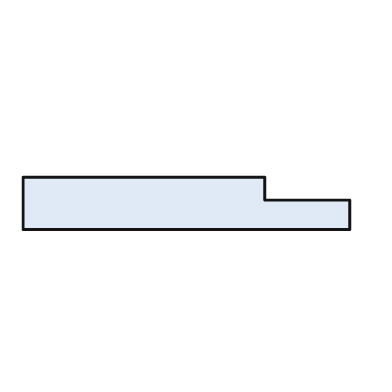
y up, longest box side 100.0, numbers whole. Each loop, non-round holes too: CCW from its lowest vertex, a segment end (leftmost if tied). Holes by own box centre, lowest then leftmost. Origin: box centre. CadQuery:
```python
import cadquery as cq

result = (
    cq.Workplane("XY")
    .moveTo(-50.0, -8.0)
    .lineTo(50.0, -8.0)
    .lineTo(50.0, 1.0)
    .lineTo(24.0, 1.0)
    .lineTo(24.0, 8.0)
    .lineTo(-50.0, 8.0)
    .close()
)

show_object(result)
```